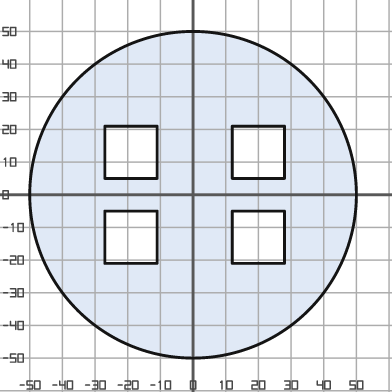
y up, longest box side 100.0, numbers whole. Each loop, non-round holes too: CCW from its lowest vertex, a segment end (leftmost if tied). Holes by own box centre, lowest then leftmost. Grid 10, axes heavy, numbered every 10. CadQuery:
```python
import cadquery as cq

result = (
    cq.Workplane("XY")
    .moveTo(0.0, 0.0)
    .circle(50.0)
    .moveTo(-27.0, -21.0)
    .lineTo(-11.0, -21.0)
    .lineTo(-11.0, -5.0)
    .lineTo(-27.0, -5.0)
    .close()
    .moveTo(12.0, -21.0)
    .lineTo(28.0, -21.0)
    .lineTo(28.0, -5.0)
    .lineTo(12.0, -5.0)
    .close()
    .moveTo(-27.0, 5.0)
    .lineTo(-11.0, 5.0)
    .lineTo(-11.0, 21.0)
    .lineTo(-27.0, 21.0)
    .close()
    .moveTo(12.0, 5.0)
    .lineTo(28.0, 5.0)
    .lineTo(28.0, 21.0)
    .lineTo(12.0, 21.0)
    .close()
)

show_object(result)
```